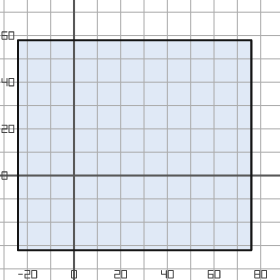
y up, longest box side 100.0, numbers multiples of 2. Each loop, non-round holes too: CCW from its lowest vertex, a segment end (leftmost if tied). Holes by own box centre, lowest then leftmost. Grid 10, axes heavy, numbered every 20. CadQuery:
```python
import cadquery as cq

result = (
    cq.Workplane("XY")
    .moveTo(-24.0, -32.0)
    .lineTo(76.0, -32.0)
    .lineTo(76.0, 58.0)
    .lineTo(-24.0, 58.0)
    .close()
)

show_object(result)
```